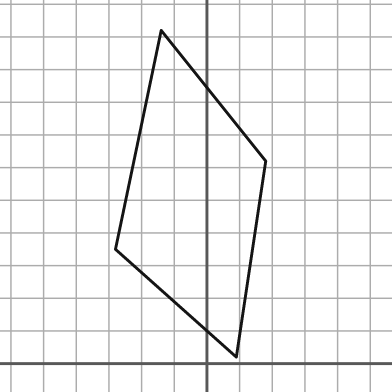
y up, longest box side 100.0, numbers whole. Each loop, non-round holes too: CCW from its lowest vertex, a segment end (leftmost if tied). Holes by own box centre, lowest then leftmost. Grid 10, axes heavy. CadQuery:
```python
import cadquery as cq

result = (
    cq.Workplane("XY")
    .moveTo(9.0, 2.0)
    .lineTo(18.0, 62.0)
    .lineTo(-14.0, 102.0)
    .lineTo(-28.0, 35.0)
    .close()
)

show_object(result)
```